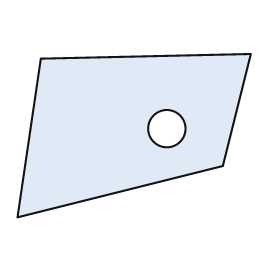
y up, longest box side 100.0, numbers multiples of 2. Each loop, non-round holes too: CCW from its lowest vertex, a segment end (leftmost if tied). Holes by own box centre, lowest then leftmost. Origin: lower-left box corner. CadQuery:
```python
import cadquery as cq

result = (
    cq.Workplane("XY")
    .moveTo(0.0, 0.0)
    .lineTo(88.0, 22.0)
    .lineTo(100.0, 70.0)
    .lineTo(10.0, 68.0)
    .close()
    .moveTo(64.0, 38.0)
    .circle(8.0)
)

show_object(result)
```